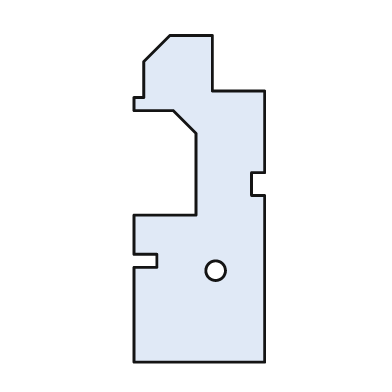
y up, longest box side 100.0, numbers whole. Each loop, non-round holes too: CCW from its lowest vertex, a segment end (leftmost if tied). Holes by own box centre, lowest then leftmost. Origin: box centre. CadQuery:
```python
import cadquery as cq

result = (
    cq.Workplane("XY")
    .moveTo(-20.0, -50.0)
    .lineTo(20.0, -50.0)
    .lineTo(20.0, 1.0)
    .lineTo(16.0, 1.0)
    .lineTo(16.0, 8.0)
    .lineTo(20.0, 8.0)
    .lineTo(20.0, 33.0)
    .lineTo(4.0, 33.0)
    .lineTo(4.0, 50.0)
    .lineTo(-9.0, 50.0)
    .lineTo(-17.0, 42.0)
    .lineTo(-17.0, 31.0)
    .lineTo(-20.0, 31.0)
    .lineTo(-20.0, 27.0)
    .lineTo(-8.0, 27.0)
    .lineTo(-1.0, 20.0)
    .lineTo(-1.0, -5.0)
    .lineTo(-20.0, -5.0)
    .lineTo(-20.0, -17.0)
    .lineTo(-13.0, -17.0)
    .lineTo(-13.0, -21.0)
    .lineTo(-20.0, -21.0)
    .close()
    .moveTo(5.0, -22.0)
    .circle(3.0)
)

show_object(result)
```